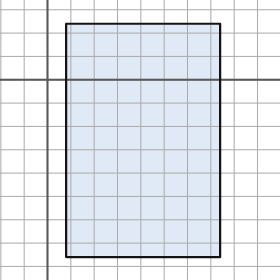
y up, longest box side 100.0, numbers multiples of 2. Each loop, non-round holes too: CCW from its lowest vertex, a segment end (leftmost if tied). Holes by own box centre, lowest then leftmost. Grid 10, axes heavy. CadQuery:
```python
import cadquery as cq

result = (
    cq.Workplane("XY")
    .moveTo(8.0, -76.0)
    .lineTo(74.0, -76.0)
    .lineTo(74.0, 24.0)
    .lineTo(8.0, 24.0)
    .close()
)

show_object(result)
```